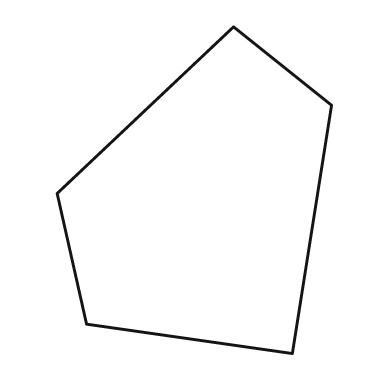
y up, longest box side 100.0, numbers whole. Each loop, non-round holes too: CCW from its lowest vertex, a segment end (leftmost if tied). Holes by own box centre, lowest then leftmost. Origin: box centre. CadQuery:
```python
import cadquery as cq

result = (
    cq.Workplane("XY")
    .moveTo(30.0, -50.0)
    .lineTo(42.0, 26.0)
    .lineTo(12.0, 50.0)
    .lineTo(-42.0, -1.0)
    .lineTo(-33.0, -41.0)
    .close()
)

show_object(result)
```